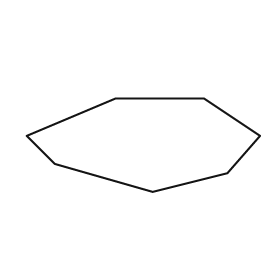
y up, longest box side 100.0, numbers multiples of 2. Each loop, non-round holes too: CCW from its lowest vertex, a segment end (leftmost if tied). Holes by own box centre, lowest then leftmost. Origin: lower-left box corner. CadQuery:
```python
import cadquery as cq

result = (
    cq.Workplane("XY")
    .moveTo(54.0, 0.0)
    .lineTo(86.0, 8.0)
    .lineTo(100.0, 24.0)
    .lineTo(76.0, 40.0)
    .lineTo(38.0, 40.0)
    .lineTo(0.0, 24.0)
    .lineTo(12.0, 12.0)
    .close()
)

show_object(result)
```